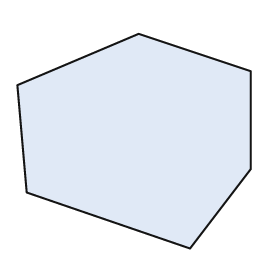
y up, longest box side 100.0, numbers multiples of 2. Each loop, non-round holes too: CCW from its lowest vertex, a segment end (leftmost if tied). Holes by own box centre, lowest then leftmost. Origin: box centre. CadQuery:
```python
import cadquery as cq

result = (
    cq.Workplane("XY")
    .moveTo(24.0, -46.0)
    .lineTo(50.0, -12.0)
    .lineTo(50.0, 30.0)
    .lineTo(2.0, 46.0)
    .lineTo(-50.0, 24.0)
    .lineTo(-46.0, -22.0)
    .close()
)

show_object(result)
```